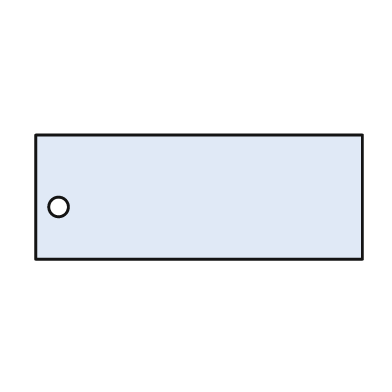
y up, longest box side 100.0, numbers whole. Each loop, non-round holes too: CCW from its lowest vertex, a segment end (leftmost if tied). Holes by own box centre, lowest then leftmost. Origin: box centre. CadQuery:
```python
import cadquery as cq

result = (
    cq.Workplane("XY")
    .moveTo(-50.0, -19.0)
    .lineTo(50.0, -19.0)
    .lineTo(50.0, 19.0)
    .lineTo(-50.0, 19.0)
    .close()
    .moveTo(-43.0, -3.0)
    .circle(3.0)
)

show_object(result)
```